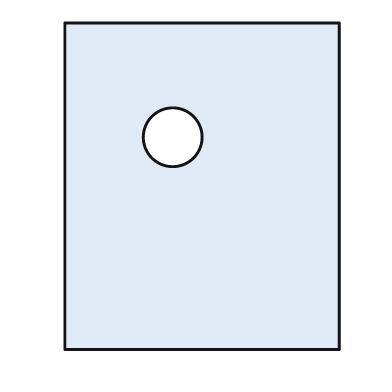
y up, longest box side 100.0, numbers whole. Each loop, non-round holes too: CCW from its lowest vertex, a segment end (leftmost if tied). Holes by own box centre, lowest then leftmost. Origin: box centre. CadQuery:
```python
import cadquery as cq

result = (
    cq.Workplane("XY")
    .moveTo(-42.0, -50.0)
    .lineTo(42.0, -50.0)
    .lineTo(42.0, 50.0)
    .lineTo(-42.0, 50.0)
    .close()
    .moveTo(-9.0, 15.0)
    .circle(9.0)
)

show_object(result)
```